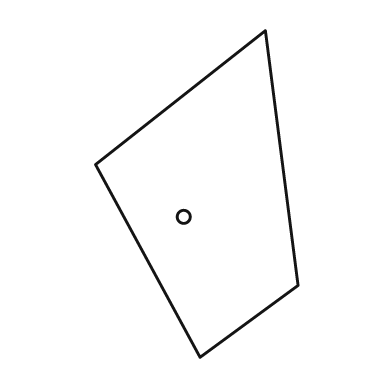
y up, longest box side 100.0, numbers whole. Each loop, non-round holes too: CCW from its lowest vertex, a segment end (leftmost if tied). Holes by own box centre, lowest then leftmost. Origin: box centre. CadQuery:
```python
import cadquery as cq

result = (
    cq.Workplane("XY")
    .moveTo(1.0, -50.0)
    .lineTo(31.0, -28.0)
    .lineTo(21.0, 50.0)
    .lineTo(-31.0, 9.0)
    .close()
    .moveTo(-4.0, -7.0)
    .circle(2.0)
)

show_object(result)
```